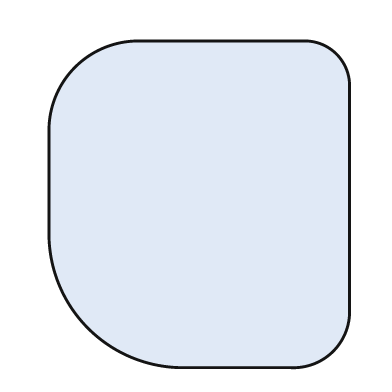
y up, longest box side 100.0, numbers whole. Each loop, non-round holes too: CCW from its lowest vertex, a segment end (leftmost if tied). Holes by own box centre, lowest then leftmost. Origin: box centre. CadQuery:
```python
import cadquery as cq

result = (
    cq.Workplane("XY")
    .moveTo(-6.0, -50.0)
    .lineTo(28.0, -50.0)
    .threePointArc((41.0, -45.0), (46.0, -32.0))
    .lineTo(46.0, 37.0)
    .threePointArc((42.0, 46.0), (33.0, 50.0))
    .lineTo(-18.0, 50.0)
    .threePointArc((-38.0, 42.0), (-46.0, 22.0))
    .lineTo(-46.0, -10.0)
    .threePointArc((-34.0, -38.0), (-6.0, -50.0))
    .close()
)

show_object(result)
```